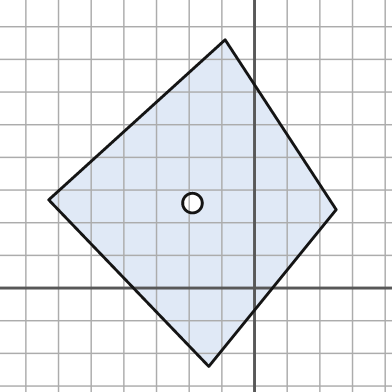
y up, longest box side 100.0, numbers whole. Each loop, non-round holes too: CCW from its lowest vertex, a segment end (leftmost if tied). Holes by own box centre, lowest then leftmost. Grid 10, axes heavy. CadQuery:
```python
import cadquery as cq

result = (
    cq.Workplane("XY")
    .moveTo(-14.0, -24.0)
    .lineTo(25.0, 24.0)
    .lineTo(-9.0, 76.0)
    .lineTo(-63.0, 27.0)
    .close()
    .moveTo(-19.0, 26.0)
    .circle(3.0)
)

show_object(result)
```